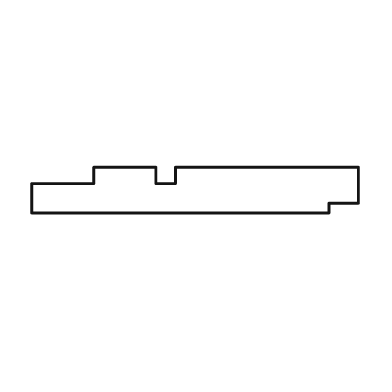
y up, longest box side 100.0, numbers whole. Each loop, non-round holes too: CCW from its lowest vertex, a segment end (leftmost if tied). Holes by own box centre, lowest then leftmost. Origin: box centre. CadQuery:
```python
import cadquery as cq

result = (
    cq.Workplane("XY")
    .moveTo(-50.0, -7.0)
    .lineTo(41.0, -7.0)
    .lineTo(41.0, -4.0)
    .lineTo(50.0, -4.0)
    .lineTo(50.0, 7.0)
    .lineTo(-6.0, 7.0)
    .lineTo(-6.0, 2.0)
    .lineTo(-12.0, 2.0)
    .lineTo(-12.0, 7.0)
    .lineTo(-31.0, 7.0)
    .lineTo(-31.0, 2.0)
    .lineTo(-50.0, 2.0)
    .close()
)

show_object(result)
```